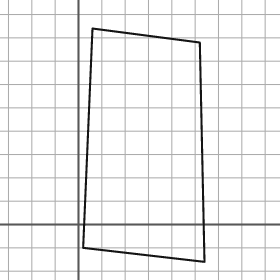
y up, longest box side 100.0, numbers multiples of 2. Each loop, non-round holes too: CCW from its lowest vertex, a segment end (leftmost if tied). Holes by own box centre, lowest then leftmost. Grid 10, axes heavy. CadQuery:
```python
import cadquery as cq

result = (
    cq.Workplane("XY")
    .moveTo(54.0, -16.0)
    .lineTo(52.0, 78.0)
    .lineTo(6.0, 84.0)
    .lineTo(2.0, -10.0)
    .close()
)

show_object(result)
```